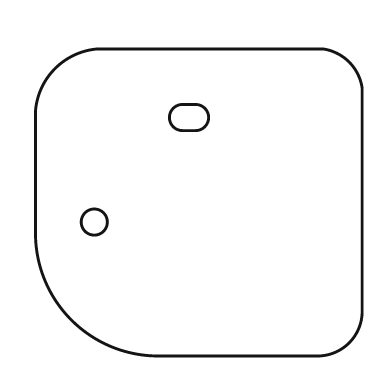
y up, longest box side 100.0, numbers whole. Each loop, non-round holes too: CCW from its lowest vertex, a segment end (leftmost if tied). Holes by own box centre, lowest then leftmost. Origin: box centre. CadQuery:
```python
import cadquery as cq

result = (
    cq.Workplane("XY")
    .moveTo(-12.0, -47.0)
    .lineTo(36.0, -47.0)
    .threePointArc((46.0, -43.0), (50.0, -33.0))
    .lineTo(50.0, 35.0)
    .threePointArc((46.0, 43.0), (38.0, 47.0))
    .lineTo(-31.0, 47.0)
    .threePointArc((-44.0, 41.0), (-50.0, 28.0))
    .lineTo(-50.0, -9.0)
    .threePointArc((-39.0, -36.0), (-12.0, -47.0))
    .close()
    .moveTo(-32.0, -6.0)
    .circle(4.0)
    .moveTo(-5.0, 22.0)
    .lineTo(-1.0, 22.0)
    .threePointArc((3.0, 26.0), (-1.0, 30.0))
    .lineTo(-5.0, 30.0)
    .threePointArc((-9.0, 26.0), (-5.0, 22.0))
    .close()
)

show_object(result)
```